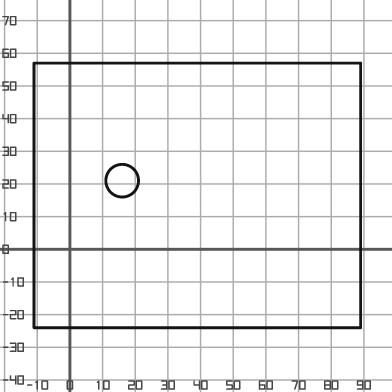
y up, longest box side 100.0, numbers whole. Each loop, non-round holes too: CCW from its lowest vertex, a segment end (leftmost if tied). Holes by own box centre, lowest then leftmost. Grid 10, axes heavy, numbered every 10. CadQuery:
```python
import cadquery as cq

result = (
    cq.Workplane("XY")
    .moveTo(-11.0, -24.0)
    .lineTo(89.0, -24.0)
    .lineTo(89.0, 57.0)
    .lineTo(-11.0, 57.0)
    .close()
    .moveTo(16.0, 21.0)
    .circle(5.0)
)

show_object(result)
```